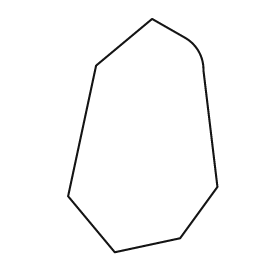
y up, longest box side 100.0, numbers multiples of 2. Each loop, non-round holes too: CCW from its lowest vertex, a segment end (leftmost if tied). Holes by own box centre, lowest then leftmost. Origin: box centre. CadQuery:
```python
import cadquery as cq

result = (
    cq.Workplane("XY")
    .moveTo(-12.0, -50.0)
    .lineTo(16.0, -44.0)
    .lineTo(32.0, -22.0)
    .lineTo(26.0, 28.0)
    .threePointArc((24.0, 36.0), (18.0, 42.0))
    .lineTo(4.0, 50.0)
    .lineTo(-20.0, 30.0)
    .lineTo(-32.0, -26.0)
    .close()
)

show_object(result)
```